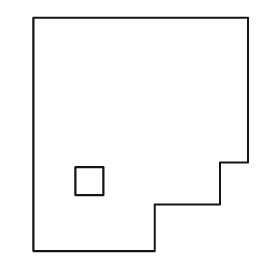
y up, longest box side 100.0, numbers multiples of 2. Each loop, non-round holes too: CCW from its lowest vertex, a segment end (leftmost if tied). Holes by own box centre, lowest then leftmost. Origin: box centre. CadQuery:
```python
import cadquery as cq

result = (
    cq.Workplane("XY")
    .moveTo(-46.0, -50.0)
    .lineTo(6.0, -50.0)
    .lineTo(6.0, -30.0)
    .lineTo(34.0, -30.0)
    .lineTo(34.0, -12.0)
    .lineTo(46.0, -12.0)
    .lineTo(46.0, 50.0)
    .lineTo(-46.0, 50.0)
    .close()
    .moveTo(-28.0, -26.0)
    .lineTo(-16.0, -26.0)
    .lineTo(-16.0, -14.0)
    .lineTo(-28.0, -14.0)
    .close()
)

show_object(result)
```